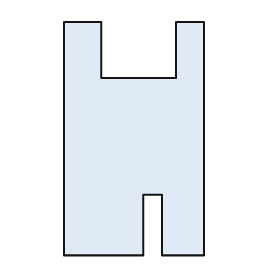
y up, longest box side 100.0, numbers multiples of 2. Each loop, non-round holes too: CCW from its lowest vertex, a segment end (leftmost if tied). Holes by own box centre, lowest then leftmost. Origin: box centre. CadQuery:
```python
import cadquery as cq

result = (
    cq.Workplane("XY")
    .moveTo(-30.0, -50.0)
    .lineTo(4.0, -50.0)
    .lineTo(4.0, -24.0)
    .lineTo(12.0, -24.0)
    .lineTo(12.0, -50.0)
    .lineTo(30.0, -50.0)
    .lineTo(30.0, 50.0)
    .lineTo(18.0, 50.0)
    .lineTo(18.0, 26.0)
    .lineTo(-14.0, 26.0)
    .lineTo(-14.0, 50.0)
    .lineTo(-30.0, 50.0)
    .close()
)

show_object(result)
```